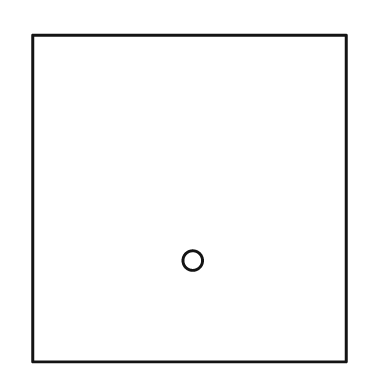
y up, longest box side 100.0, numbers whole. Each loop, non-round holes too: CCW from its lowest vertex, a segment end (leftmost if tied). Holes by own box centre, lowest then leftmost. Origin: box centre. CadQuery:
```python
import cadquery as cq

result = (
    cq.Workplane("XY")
    .moveTo(-48.0, -50.0)
    .lineTo(48.0, -50.0)
    .lineTo(48.0, 50.0)
    .lineTo(-48.0, 50.0)
    .close()
    .moveTo(1.0, -19.0)
    .circle(3.0)
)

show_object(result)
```